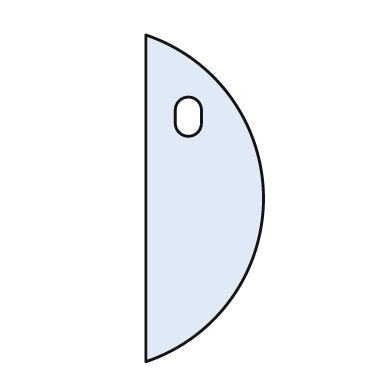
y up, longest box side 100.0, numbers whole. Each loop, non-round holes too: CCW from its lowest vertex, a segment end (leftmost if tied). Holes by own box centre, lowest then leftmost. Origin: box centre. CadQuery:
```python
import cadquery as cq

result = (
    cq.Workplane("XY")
    .moveTo(-18.0, -50.0)
    .threePointArc((18.0, 0.0), (-18.0, 50.0))
    .close()
    .moveTo(-9.0, 23.0)
    .threePointArc((-5.0, 19.0), (-1.0, 23.0))
    .lineTo(-1.0, 27.0)
    .threePointArc((-5.0, 31.0), (-9.0, 27.0))
    .close()
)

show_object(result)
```